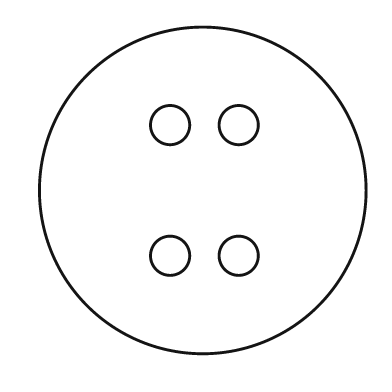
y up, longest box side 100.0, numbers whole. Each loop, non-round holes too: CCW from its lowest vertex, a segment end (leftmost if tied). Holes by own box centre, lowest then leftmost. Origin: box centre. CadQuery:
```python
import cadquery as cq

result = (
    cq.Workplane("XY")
    .moveTo(0.0, 0.0)
    .circle(50.0)
    .moveTo(-10.0, -20.0)
    .circle(6.0)
    .moveTo(11.0, -20.0)
    .circle(6.0)
    .moveTo(-10.0, 20.0)
    .circle(6.0)
    .moveTo(11.0, 20.0)
    .circle(6.0)
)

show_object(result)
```